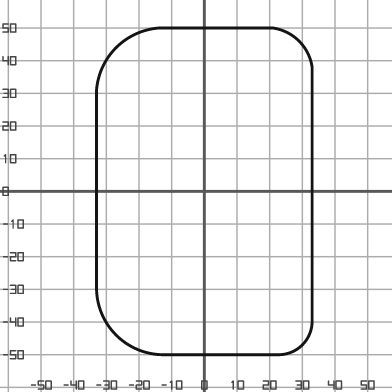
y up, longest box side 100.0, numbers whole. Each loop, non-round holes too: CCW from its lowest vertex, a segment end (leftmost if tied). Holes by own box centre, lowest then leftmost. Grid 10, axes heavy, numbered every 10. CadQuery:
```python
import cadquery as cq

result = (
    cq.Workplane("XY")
    .moveTo(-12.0, -50.0)
    .lineTo(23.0, -50.0)
    .threePointArc((30.0, -47.0), (33.0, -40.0))
    .lineTo(33.0, 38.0)
    .threePointArc((29.0, 46.0), (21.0, 50.0))
    .lineTo(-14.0, 50.0)
    .threePointArc((-27.0, 44.0), (-33.0, 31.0))
    .lineTo(-33.0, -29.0)
    .threePointArc((-27.0, -44.0), (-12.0, -50.0))
    .close()
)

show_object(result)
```